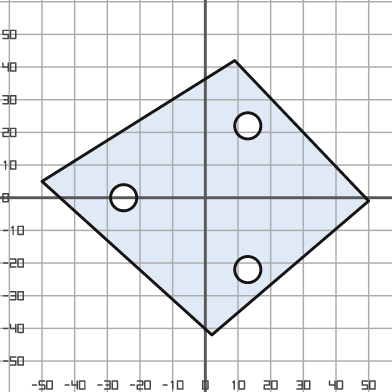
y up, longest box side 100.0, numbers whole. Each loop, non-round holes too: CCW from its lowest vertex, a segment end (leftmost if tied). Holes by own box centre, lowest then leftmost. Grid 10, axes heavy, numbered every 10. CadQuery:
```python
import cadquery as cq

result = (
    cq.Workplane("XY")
    .moveTo(2.0, -42.0)
    .lineTo(50.0, -1.0)
    .lineTo(9.0, 42.0)
    .lineTo(-50.0, 5.0)
    .close()
    .moveTo(13.0, -22.0)
    .circle(4.0)
    .moveTo(-25.0, 0.0)
    .circle(4.0)
    .moveTo(13.0, 22.0)
    .circle(4.0)
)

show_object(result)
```